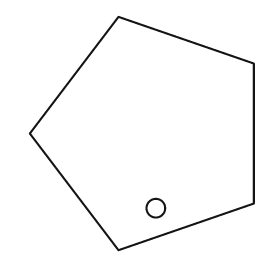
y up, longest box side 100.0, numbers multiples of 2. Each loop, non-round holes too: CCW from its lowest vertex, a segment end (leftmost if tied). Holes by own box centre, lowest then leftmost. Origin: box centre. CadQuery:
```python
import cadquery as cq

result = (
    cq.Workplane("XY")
    .moveTo(-10.0, -50.0)
    .lineTo(48.0, -30.0)
    .lineTo(48.0, 30.0)
    .lineTo(-10.0, 50.0)
    .lineTo(-48.0, 0.0)
    .close()
    .moveTo(6.0, -32.0)
    .circle(4.0)
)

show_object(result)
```